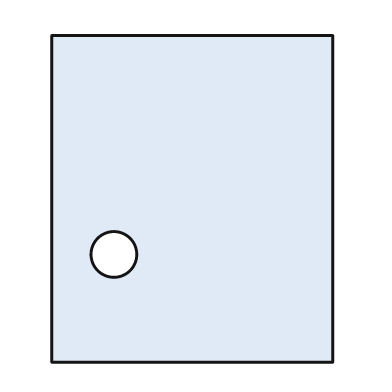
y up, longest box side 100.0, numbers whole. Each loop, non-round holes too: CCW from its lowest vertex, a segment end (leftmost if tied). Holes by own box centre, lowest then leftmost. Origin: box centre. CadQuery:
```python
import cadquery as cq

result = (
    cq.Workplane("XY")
    .moveTo(-43.0, -50.0)
    .lineTo(43.0, -50.0)
    .lineTo(43.0, 50.0)
    .lineTo(-43.0, 50.0)
    .close()
    .moveTo(-24.0, -17.0)
    .circle(7.0)
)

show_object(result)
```